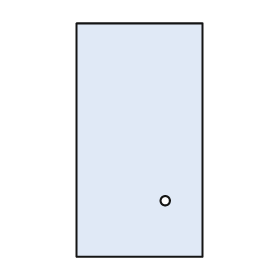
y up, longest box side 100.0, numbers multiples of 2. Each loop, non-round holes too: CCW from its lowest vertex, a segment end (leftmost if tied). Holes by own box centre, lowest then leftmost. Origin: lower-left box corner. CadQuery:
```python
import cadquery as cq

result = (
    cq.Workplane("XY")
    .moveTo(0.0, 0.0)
    .lineTo(54.0, 0.0)
    .lineTo(54.0, 100.0)
    .lineTo(0.0, 100.0)
    .close()
    .moveTo(38.0, 24.0)
    .circle(2.0)
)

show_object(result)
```